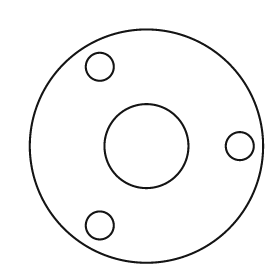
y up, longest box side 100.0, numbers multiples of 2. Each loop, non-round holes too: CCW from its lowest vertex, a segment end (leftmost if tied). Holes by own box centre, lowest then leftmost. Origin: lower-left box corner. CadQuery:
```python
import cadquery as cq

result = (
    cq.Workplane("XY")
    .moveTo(50.0, 50.0)
    .circle(50.0)
    .moveTo(30.0, 16.0)
    .circle(6.0)
    .moveTo(50.0, 50.0)
    .circle(18.0)
    .moveTo(90.0, 50.0)
    .circle(6.0)
    .moveTo(30.0, 84.0)
    .circle(6.0)
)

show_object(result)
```